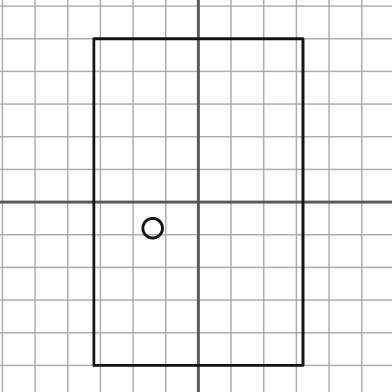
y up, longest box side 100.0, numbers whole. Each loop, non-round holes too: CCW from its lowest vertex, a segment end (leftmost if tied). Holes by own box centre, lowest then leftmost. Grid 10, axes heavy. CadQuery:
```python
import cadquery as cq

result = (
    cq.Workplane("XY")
    .moveTo(-32.0, -50.0)
    .lineTo(32.0, -50.0)
    .lineTo(32.0, 50.0)
    .lineTo(-32.0, 50.0)
    .close()
    .moveTo(-14.0, -8.0)
    .circle(3.0)
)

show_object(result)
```